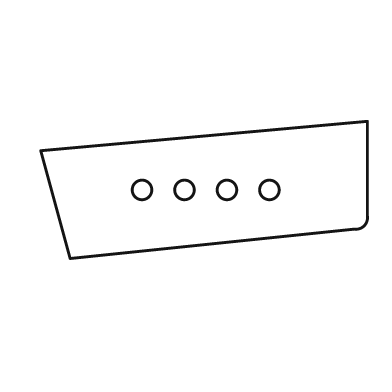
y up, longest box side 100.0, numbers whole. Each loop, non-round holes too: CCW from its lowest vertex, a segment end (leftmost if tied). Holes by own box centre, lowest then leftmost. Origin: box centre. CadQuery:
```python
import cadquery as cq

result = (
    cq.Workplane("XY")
    .moveTo(-41.0, -21.0)
    .lineTo(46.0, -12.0)
    .threePointArc((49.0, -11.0), (50.0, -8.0))
    .lineTo(50.0, 21.0)
    .lineTo(-50.0, 12.0)
    .close()
    .moveTo(-19.0, 0.0)
    .circle(3.0)
    .moveTo(-6.0, 0.0)
    .circle(3.0)
    .moveTo(7.0, 0.0)
    .circle(3.0)
    .moveTo(20.0, 0.0)
    .circle(3.0)
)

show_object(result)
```